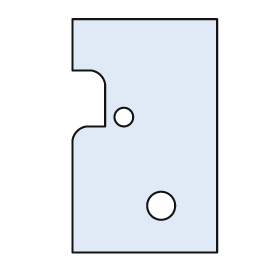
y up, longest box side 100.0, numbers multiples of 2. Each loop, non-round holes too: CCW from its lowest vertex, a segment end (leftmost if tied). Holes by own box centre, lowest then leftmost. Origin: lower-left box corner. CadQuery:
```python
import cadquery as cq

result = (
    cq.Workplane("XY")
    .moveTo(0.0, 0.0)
    .lineTo(62.0, 0.0)
    .lineTo(62.0, 100.0)
    .lineTo(0.0, 100.0)
    .lineTo(0.0, 78.0)
    .lineTo(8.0, 78.0)
    .threePointArc((12.0, 76.0), (14.0, 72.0))
    .lineTo(14.0, 54.0)
    .lineTo(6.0, 54.0)
    .threePointArc((2.0, 52.0), (0.0, 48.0))
    .close()
    .moveTo(38.0, 20.0)
    .circle(6.0)
    .moveTo(22.0, 58.0)
    .circle(4.0)
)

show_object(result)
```